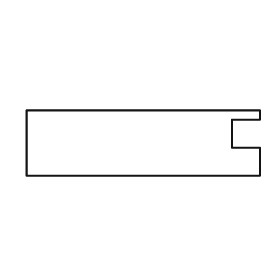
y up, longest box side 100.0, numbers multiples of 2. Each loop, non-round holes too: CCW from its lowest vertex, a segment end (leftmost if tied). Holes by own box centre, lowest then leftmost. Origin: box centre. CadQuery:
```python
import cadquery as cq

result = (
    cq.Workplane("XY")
    .moveTo(-50.0, -14.0)
    .lineTo(50.0, -14.0)
    .lineTo(50.0, -2.0)
    .lineTo(38.0, -2.0)
    .lineTo(38.0, 10.0)
    .lineTo(50.0, 10.0)
    .lineTo(50.0, 14.0)
    .lineTo(-50.0, 14.0)
    .close()
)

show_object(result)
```